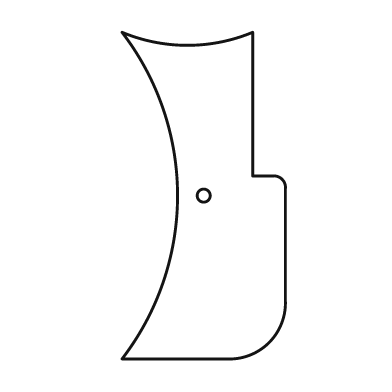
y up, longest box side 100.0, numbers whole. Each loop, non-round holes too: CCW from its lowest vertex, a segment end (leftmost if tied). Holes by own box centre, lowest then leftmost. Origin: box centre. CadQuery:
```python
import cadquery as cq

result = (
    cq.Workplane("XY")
    .moveTo(-25.0, -50.0)
    .lineTo(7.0, -50.0)
    .threePointArc((20.0, -45.0), (25.0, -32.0))
    .lineTo(25.0, 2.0)
    .threePointArc((24.0, 5.0), (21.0, 6.0))
    .lineTo(15.0, 6.0)
    .lineTo(15.0, 50.0)
    .threePointArc((-5.0, 46.0), (-25.0, 50.0))
    .threePointArc((-8.0, 0.0), (-25.0, -50.0))
    .close()
    .moveTo(0.0, 0.0)
    .circle(2.0)
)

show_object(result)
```